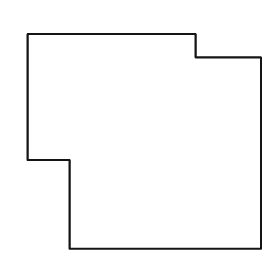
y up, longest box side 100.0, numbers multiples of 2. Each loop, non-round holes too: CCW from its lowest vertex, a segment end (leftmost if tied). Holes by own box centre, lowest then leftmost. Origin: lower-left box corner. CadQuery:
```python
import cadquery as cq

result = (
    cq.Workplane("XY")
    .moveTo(18.0, 0.0)
    .lineTo(100.0, 0.0)
    .lineTo(100.0, 82.0)
    .lineTo(72.0, 82.0)
    .lineTo(72.0, 92.0)
    .lineTo(0.0, 92.0)
    .lineTo(0.0, 38.0)
    .lineTo(18.0, 38.0)
    .close()
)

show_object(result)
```